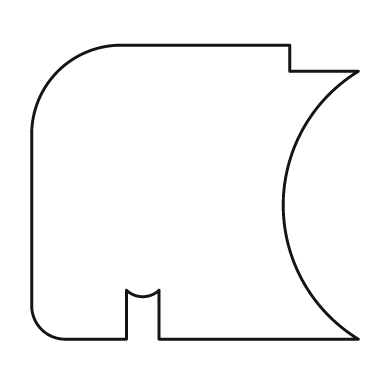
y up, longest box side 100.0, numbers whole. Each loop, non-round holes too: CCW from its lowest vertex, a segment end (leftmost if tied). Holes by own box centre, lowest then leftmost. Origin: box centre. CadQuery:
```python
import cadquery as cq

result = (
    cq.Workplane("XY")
    .moveTo(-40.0, -45.0)
    .lineTo(-21.0, -45.0)
    .lineTo(-21.0, -30.0)
    .threePointArc((-16.0, -32.0), (-11.0, -30.0))
    .lineTo(-11.0, -45.0)
    .lineTo(50.0, -45.0)
    .threePointArc((27.0, -4.0), (50.0, 37.0))
    .lineTo(29.0, 37.0)
    .lineTo(29.0, 45.0)
    .lineTo(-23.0, 45.0)
    .threePointArc((-42.0, 37.0), (-50.0, 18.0))
    .lineTo(-50.0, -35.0)
    .threePointArc((-47.0, -42.0), (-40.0, -45.0))
    .close()
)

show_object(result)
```